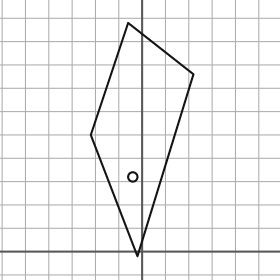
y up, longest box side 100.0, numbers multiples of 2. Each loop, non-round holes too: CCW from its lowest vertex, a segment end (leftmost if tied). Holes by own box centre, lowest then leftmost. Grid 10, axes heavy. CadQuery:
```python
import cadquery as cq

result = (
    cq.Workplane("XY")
    .moveTo(-2.0, -2.0)
    .lineTo(22.0, 76.0)
    .lineTo(-6.0, 98.0)
    .lineTo(-22.0, 50.0)
    .close()
    .moveTo(-4.0, 32.0)
    .circle(2.0)
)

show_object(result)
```